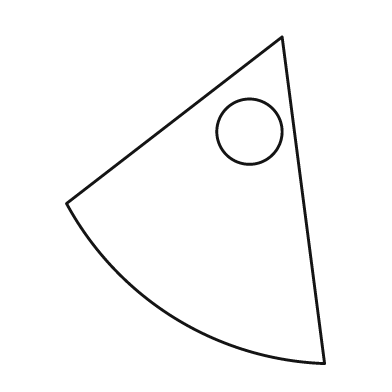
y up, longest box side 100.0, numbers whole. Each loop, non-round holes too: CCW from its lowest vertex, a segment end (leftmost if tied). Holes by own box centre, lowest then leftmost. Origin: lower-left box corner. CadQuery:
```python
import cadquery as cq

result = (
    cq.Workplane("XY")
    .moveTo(79.0, 0.0)
    .lineTo(66.0, 100.0)
    .lineTo(0.0, 49.0)
    .threePointArc((33.0, 14.0), (79.0, 0.0))
    .close()
    .moveTo(56.0, 71.0)
    .circle(10.0)
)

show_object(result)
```